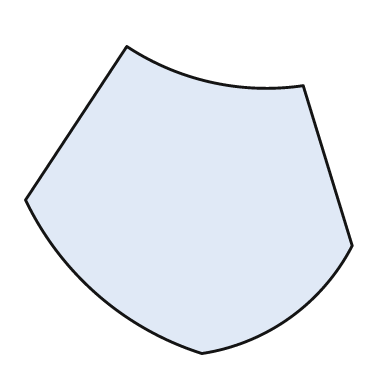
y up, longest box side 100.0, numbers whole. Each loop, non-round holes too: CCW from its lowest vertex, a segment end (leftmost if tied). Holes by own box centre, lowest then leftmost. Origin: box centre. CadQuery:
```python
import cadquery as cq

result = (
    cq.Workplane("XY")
    .moveTo(4.0, -47.0)
    .threePointArc((31.0, -36.0), (50.0, -14.0))
    .lineTo(35.0, 35.0)
    .threePointArc((7.0, 36.0), (-19.0, 47.0))
    .lineTo(-50.0, 0.0)
    .threePointArc((-28.0, -29.0), (4.0, -47.0))
    .close()
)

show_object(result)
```